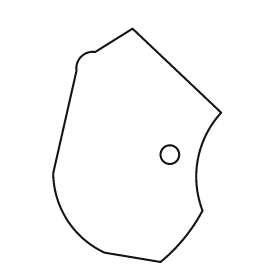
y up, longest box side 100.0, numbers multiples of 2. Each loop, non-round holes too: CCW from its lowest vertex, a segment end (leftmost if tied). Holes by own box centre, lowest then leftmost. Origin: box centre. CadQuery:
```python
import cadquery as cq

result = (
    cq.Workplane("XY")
    .moveTo(10.0, -50.0)
    .threePointArc((20.0, -40.0), (28.0, -28.0))
    .threePointArc((26.0, -6.0), (36.0, 14.0))
    .lineTo(-2.0, 50.0)
    .lineTo(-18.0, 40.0)
    .threePointArc((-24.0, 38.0), (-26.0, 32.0))
    .lineTo(-36.0, -12.0)
    .threePointArc((-30.0, -32.0), (-14.0, -46.0))
    .close()
    .moveTo(14.0, -4.0)
    .circle(4.0)
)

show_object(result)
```